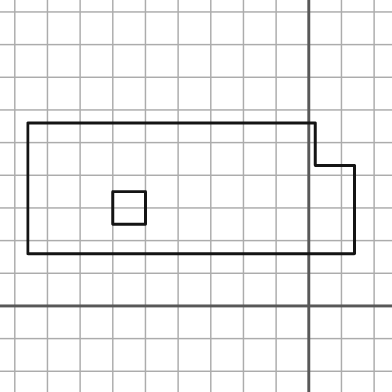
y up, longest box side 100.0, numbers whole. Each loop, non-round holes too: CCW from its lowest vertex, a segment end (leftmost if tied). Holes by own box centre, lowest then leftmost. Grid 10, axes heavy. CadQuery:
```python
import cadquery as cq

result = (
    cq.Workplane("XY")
    .moveTo(-86.0, 16.0)
    .lineTo(14.0, 16.0)
    .lineTo(14.0, 43.0)
    .lineTo(2.0, 43.0)
    .lineTo(2.0, 56.0)
    .lineTo(-86.0, 56.0)
    .close()
    .moveTo(-60.0, 25.0)
    .lineTo(-50.0, 25.0)
    .lineTo(-50.0, 35.0)
    .lineTo(-60.0, 35.0)
    .close()
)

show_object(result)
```